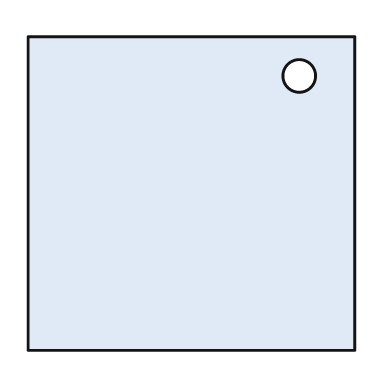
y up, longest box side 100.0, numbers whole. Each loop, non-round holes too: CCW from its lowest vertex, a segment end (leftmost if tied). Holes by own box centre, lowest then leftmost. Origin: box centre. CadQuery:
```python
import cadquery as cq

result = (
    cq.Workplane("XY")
    .moveTo(-50.0, -48.0)
    .lineTo(50.0, -48.0)
    .lineTo(50.0, 48.0)
    .lineTo(-50.0, 48.0)
    .close()
    .moveTo(33.0, 36.0)
    .circle(5.0)
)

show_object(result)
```